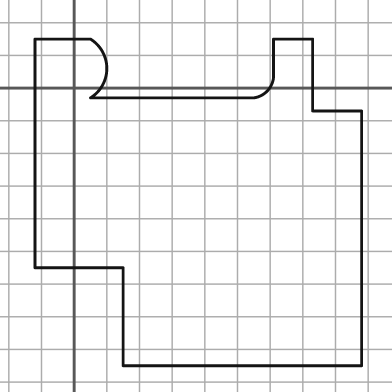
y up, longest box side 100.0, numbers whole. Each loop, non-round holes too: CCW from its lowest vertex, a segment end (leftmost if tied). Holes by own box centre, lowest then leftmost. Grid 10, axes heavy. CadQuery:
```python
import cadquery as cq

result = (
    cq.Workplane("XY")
    .moveTo(15.0, -85.0)
    .lineTo(88.0, -85.0)
    .lineTo(88.0, -7.0)
    .lineTo(73.0, -7.0)
    .lineTo(73.0, 15.0)
    .lineTo(61.0, 15.0)
    .lineTo(61.0, 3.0)
    .threePointArc((59.0, -1.0), (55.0, -3.0))
    .lineTo(5.0, -3.0)
    .threePointArc((10.0, 6.0), (5.0, 15.0))
    .lineTo(-12.0, 15.0)
    .lineTo(-12.0, -55.0)
    .lineTo(15.0, -55.0)
    .close()
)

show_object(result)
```